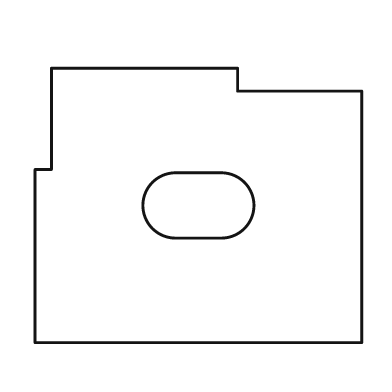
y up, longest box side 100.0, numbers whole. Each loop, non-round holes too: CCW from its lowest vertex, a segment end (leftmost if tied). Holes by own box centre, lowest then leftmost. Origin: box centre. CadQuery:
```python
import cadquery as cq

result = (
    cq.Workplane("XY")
    .moveTo(-50.0, -42.0)
    .lineTo(50.0, -42.0)
    .lineTo(50.0, 35.0)
    .lineTo(12.0, 35.0)
    .lineTo(12.0, 42.0)
    .lineTo(-45.0, 42.0)
    .lineTo(-45.0, 11.0)
    .lineTo(-50.0, 11.0)
    .close()
    .moveTo(-7.0, -10.0)
    .lineTo(7.0, -10.0)
    .threePointArc((17.0, 0.0), (7.0, 10.0))
    .lineTo(-7.0, 10.0)
    .threePointArc((-17.0, 0.0), (-7.0, -10.0))
    .close()
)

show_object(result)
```